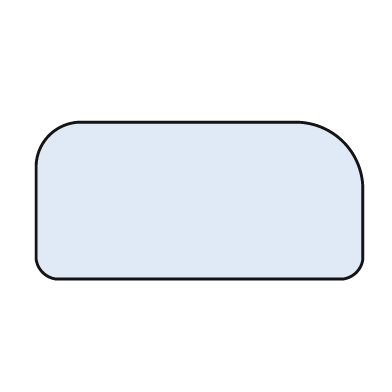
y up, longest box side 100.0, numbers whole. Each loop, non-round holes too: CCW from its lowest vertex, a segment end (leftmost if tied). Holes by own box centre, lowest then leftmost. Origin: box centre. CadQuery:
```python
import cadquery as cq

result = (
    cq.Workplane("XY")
    .moveTo(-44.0, -24.0)
    .lineTo(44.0, -24.0)
    .threePointArc((48.0, -22.0), (50.0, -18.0))
    .lineTo(50.0, 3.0)
    .threePointArc((44.0, 18.0), (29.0, 24.0))
    .lineTo(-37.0, 24.0)
    .threePointArc((-46.0, 20.0), (-50.0, 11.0))
    .lineTo(-50.0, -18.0)
    .threePointArc((-48.0, -22.0), (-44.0, -24.0))
    .close()
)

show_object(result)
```